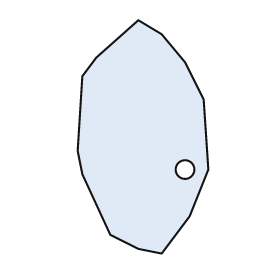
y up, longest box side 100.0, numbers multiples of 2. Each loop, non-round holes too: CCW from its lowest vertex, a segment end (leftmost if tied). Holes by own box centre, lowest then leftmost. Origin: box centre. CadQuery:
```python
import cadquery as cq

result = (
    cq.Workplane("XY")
    .moveTo(8.0, -50.0)
    .lineTo(20.0, -34.0)
    .lineTo(28.0, -14.0)
    .lineTo(26.0, 16.0)
    .lineTo(18.0, 32.0)
    .lineTo(8.0, 44.0)
    .lineTo(-2.0, 50.0)
    .lineTo(-20.0, 34.0)
    .lineTo(-26.0, 26.0)
    .lineTo(-28.0, -6.0)
    .lineTo(-26.0, -16.0)
    .lineTo(-14.0, -42.0)
    .lineTo(-2.0, -48.0)
    .close()
    .moveTo(18.0, -14.0)
    .circle(4.0)
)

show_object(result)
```